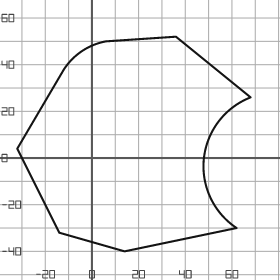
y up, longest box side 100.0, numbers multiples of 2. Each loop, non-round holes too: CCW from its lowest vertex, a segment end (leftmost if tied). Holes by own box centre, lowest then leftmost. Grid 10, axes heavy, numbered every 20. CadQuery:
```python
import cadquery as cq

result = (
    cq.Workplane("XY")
    .moveTo(14.0, -40.0)
    .lineTo(62.0, -30.0)
    .threePointArc((48.0, 0.0), (68.0, 26.0))
    .lineTo(36.0, 52.0)
    .lineTo(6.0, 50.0)
    .threePointArc((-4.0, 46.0), (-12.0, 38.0))
    .lineTo(-32.0, 4.0)
    .lineTo(-14.0, -32.0)
    .close()
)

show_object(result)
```